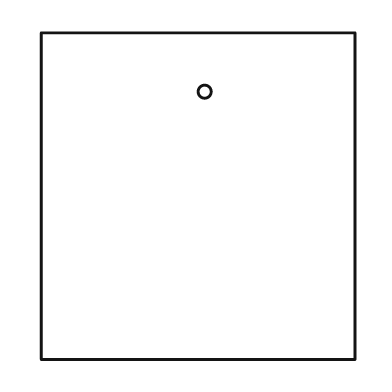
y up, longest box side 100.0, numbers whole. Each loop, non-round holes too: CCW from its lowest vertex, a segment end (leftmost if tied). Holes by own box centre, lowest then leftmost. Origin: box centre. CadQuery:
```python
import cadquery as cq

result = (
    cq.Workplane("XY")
    .moveTo(-48.0, -50.0)
    .lineTo(48.0, -50.0)
    .lineTo(48.0, 50.0)
    .lineTo(-48.0, 50.0)
    .close()
    .moveTo(2.0, 32.0)
    .circle(2.0)
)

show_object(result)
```